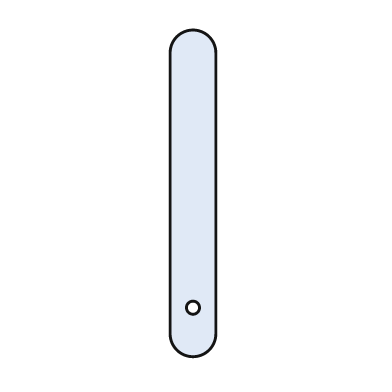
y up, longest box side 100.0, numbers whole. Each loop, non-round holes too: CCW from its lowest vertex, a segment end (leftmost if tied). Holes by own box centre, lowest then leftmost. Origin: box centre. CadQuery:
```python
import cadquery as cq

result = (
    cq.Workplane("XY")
    .moveTo(-7.0, -43.0)
    .threePointArc((0.0, -50.0), (7.0, -43.0))
    .lineTo(7.0, 43.0)
    .threePointArc((0.0, 50.0), (-7.0, 43.0))
    .close()
    .moveTo(0.0, -35.0)
    .circle(2.0)
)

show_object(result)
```